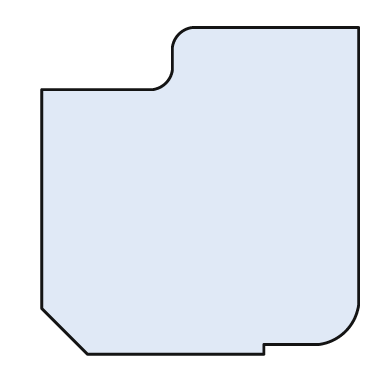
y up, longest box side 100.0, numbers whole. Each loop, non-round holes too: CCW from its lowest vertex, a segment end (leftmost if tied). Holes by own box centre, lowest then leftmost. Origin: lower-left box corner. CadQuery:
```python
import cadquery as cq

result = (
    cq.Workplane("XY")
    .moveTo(14.0, 0.0)
    .lineTo(68.0, 0.0)
    .lineTo(68.0, 3.0)
    .lineTo(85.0, 3.0)
    .threePointArc((93.0, 7.0), (97.0, 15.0))
    .lineTo(97.0, 100.0)
    .lineTo(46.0, 100.0)
    .threePointArc((42.0, 98.0), (40.0, 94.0))
    .lineTo(40.0, 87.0)
    .threePointArc((38.0, 83.0), (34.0, 81.0))
    .lineTo(0.0, 81.0)
    .lineTo(0.0, 14.0)
    .close()
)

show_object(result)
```